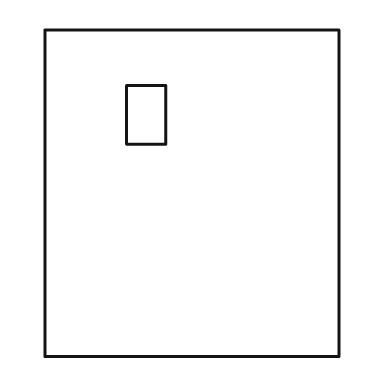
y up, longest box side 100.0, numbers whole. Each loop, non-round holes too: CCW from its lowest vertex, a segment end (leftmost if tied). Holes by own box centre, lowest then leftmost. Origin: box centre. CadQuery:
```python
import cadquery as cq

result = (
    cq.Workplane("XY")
    .moveTo(-45.0, -50.0)
    .lineTo(45.0, -50.0)
    .lineTo(45.0, 50.0)
    .lineTo(-45.0, 50.0)
    .close()
    .moveTo(-20.0, 15.0)
    .lineTo(-8.0, 15.0)
    .lineTo(-8.0, 33.0)
    .lineTo(-20.0, 33.0)
    .close()
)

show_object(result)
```